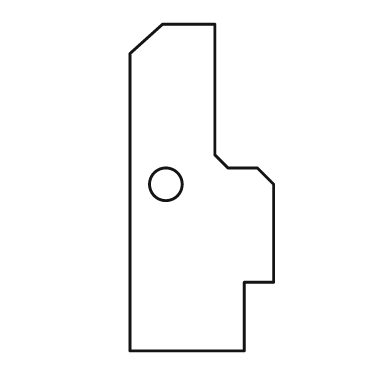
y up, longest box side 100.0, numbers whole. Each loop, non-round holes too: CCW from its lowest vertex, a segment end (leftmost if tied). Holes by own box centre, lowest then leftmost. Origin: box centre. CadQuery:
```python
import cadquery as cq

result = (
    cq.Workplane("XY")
    .moveTo(-22.0, -50.0)
    .lineTo(13.0, -50.0)
    .lineTo(13.0, -29.0)
    .lineTo(22.0, -29.0)
    .lineTo(22.0, 1.0)
    .lineTo(17.0, 6.0)
    .lineTo(8.0, 6.0)
    .lineTo(4.0, 10.0)
    .lineTo(4.0, 50.0)
    .lineTo(-12.0, 50.0)
    .lineTo(-22.0, 41.0)
    .close()
    .moveTo(-11.0, 1.0)
    .circle(5.0)
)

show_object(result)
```